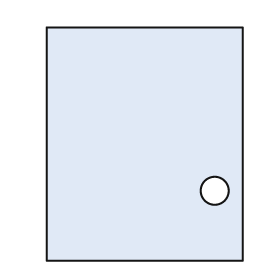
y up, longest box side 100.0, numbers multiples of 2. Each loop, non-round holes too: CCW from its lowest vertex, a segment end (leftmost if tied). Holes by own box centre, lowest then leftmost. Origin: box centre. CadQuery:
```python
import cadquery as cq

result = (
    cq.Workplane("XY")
    .moveTo(-42.0, -50.0)
    .lineTo(42.0, -50.0)
    .lineTo(42.0, 50.0)
    .lineTo(-42.0, 50.0)
    .close()
    .moveTo(30.0, -20.0)
    .circle(6.0)
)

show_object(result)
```